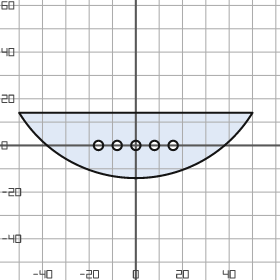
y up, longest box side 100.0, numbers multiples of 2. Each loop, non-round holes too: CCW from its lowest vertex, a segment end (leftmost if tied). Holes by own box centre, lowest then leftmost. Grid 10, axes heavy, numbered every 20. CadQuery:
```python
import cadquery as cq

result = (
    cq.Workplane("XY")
    .moveTo(-50.0, 14.0)
    .threePointArc((0.0, -14.0), (50.0, 14.0))
    .close()
    .moveTo(-16.0, 0.0)
    .circle(2.0)
    .moveTo(-8.0, 0.0)
    .circle(2.0)
    .moveTo(0.0, 0.0)
    .circle(2.0)
    .moveTo(8.0, 0.0)
    .circle(2.0)
    .moveTo(16.0, 0.0)
    .circle(2.0)
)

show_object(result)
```